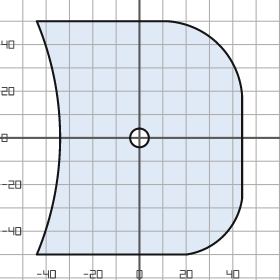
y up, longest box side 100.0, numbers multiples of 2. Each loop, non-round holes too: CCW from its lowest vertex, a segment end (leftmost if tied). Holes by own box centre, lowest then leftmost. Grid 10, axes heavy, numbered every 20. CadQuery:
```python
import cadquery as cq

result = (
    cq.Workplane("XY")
    .moveTo(-44.0, -50.0)
    .lineTo(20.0, -50.0)
    .threePointArc((36.0, -42.0), (44.0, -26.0))
    .lineTo(44.0, 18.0)
    .threePointArc((34.0, 40.0), (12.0, 50.0))
    .lineTo(-44.0, 50.0)
    .threePointArc((-34.0, 0.0), (-44.0, -50.0))
    .close()
    .moveTo(0.0, 0.0)
    .circle(4.0)
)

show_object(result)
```